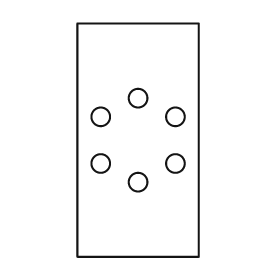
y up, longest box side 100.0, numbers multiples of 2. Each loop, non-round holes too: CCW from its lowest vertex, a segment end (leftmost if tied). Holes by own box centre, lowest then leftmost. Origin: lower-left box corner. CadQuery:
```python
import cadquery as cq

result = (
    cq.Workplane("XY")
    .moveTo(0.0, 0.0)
    .lineTo(52.0, 0.0)
    .lineTo(52.0, 100.0)
    .lineTo(0.0, 100.0)
    .close()
    .moveTo(26.0, 32.0)
    .circle(4.0)
    .moveTo(10.0, 40.0)
    .circle(4.0)
    .moveTo(42.0, 40.0)
    .circle(4.0)
    .moveTo(10.0, 60.0)
    .circle(4.0)
    .moveTo(42.0, 60.0)
    .circle(4.0)
    .moveTo(26.0, 68.0)
    .circle(4.0)
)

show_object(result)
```